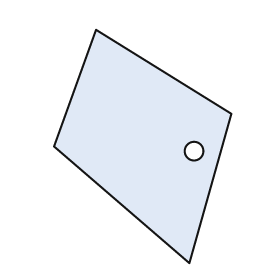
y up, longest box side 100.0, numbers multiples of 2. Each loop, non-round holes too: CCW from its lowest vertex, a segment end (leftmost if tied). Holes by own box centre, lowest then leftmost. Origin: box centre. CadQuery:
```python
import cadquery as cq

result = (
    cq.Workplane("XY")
    .moveTo(20.0, -50.0)
    .lineTo(38.0, 14.0)
    .lineTo(-20.0, 50.0)
    .lineTo(-38.0, 0.0)
    .close()
    .moveTo(22.0, -2.0)
    .circle(4.0)
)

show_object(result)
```